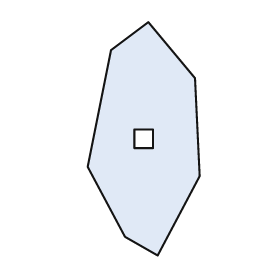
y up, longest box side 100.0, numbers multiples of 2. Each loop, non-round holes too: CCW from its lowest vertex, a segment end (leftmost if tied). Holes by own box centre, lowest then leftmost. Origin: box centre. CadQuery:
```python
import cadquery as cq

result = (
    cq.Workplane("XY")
    .moveTo(6.0, -50.0)
    .lineTo(24.0, -16.0)
    .lineTo(22.0, 26.0)
    .lineTo(2.0, 50.0)
    .lineTo(-14.0, 38.0)
    .lineTo(-24.0, -12.0)
    .lineTo(-8.0, -42.0)
    .close()
    .moveTo(-4.0, -4.0)
    .lineTo(4.0, -4.0)
    .lineTo(4.0, 4.0)
    .lineTo(-4.0, 4.0)
    .close()
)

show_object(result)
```